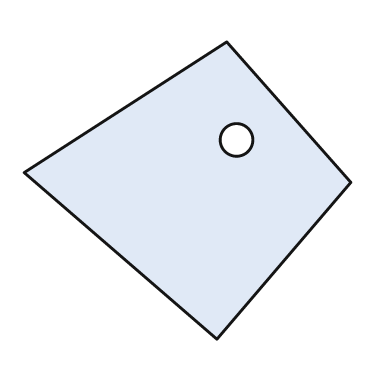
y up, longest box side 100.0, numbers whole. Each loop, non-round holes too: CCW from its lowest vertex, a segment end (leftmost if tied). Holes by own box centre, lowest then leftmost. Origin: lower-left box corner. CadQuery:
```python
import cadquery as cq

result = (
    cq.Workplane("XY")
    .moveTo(59.0, 0.0)
    .lineTo(100.0, 48.0)
    .lineTo(62.0, 91.0)
    .lineTo(0.0, 51.0)
    .close()
    .moveTo(65.0, 61.0)
    .circle(5.0)
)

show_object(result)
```